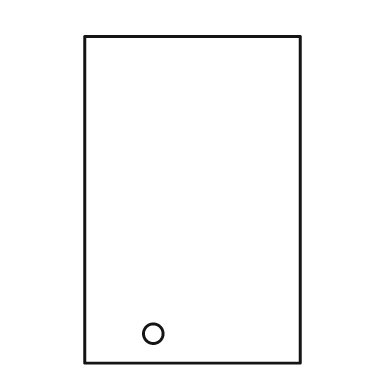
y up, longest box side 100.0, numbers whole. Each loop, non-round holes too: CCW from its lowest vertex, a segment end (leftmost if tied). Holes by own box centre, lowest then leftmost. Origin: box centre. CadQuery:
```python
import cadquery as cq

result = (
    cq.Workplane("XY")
    .moveTo(-33.0, -50.0)
    .lineTo(33.0, -50.0)
    .lineTo(33.0, 50.0)
    .lineTo(-33.0, 50.0)
    .close()
    .moveTo(-12.0, -41.0)
    .circle(3.0)
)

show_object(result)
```